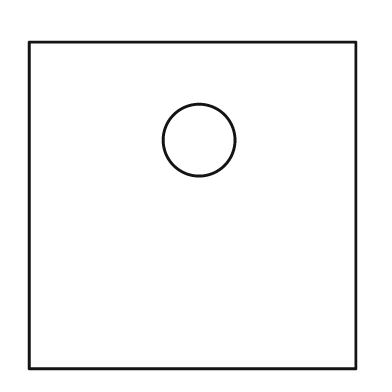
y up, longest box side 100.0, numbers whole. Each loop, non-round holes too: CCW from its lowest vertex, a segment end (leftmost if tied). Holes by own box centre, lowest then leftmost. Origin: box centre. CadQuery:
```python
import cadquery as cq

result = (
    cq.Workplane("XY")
    .moveTo(-50.0, -50.0)
    .lineTo(50.0, -50.0)
    .lineTo(50.0, 50.0)
    .lineTo(-50.0, 50.0)
    .close()
    .moveTo(2.0, 20.0)
    .circle(11.0)
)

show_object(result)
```